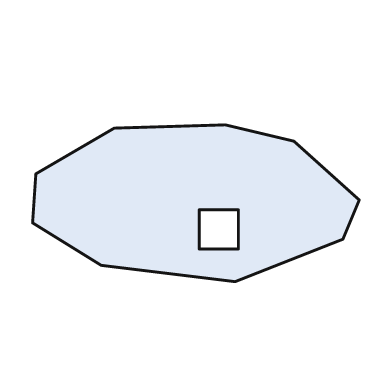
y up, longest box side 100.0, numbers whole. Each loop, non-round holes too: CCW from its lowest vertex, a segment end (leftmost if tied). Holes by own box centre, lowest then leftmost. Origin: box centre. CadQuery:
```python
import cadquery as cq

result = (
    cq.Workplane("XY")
    .moveTo(12.0, -24.0)
    .lineTo(45.0, -11.0)
    .lineTo(50.0, 1.0)
    .lineTo(30.0, 19.0)
    .lineTo(9.0, 24.0)
    .lineTo(-25.0, 23.0)
    .lineTo(-49.0, 9.0)
    .lineTo(-50.0, -6.0)
    .lineTo(-29.0, -19.0)
    .close()
    .moveTo(1.0, -14.0)
    .lineTo(13.0, -14.0)
    .lineTo(13.0, -2.0)
    .lineTo(1.0, -2.0)
    .close()
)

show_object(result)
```